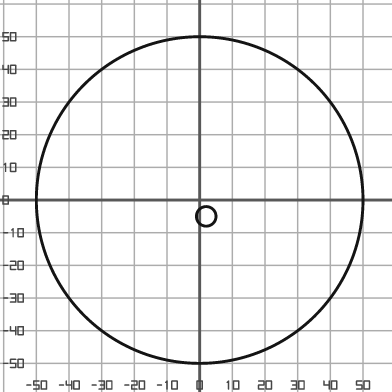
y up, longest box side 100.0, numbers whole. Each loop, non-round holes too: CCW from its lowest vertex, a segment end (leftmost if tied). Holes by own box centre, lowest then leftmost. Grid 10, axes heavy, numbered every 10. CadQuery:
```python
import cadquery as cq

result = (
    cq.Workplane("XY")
    .moveTo(0.0, 0.0)
    .circle(50.0)
    .moveTo(2.0, -5.0)
    .circle(3.0)
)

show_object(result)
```